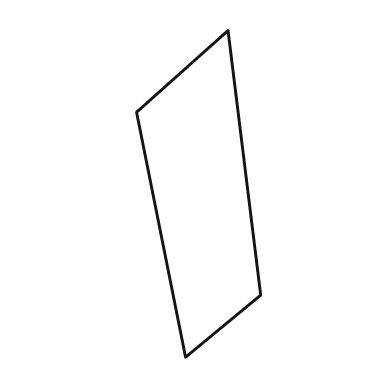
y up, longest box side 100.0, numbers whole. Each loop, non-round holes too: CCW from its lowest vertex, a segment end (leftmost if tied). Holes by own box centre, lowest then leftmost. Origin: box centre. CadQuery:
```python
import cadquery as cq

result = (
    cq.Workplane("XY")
    .moveTo(-4.0, -50.0)
    .lineTo(19.0, -31.0)
    .lineTo(9.0, 50.0)
    .lineTo(-19.0, 25.0)
    .close()
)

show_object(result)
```